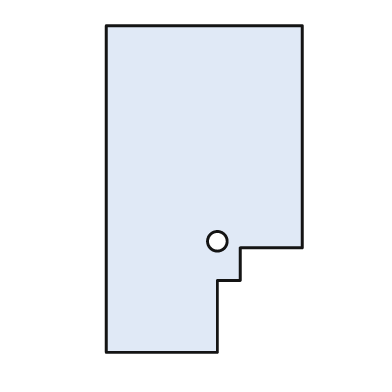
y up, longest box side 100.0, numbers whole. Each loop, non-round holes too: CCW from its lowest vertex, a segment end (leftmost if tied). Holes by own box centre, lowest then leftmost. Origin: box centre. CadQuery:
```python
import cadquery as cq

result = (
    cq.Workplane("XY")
    .moveTo(-30.0, -50.0)
    .lineTo(4.0, -50.0)
    .lineTo(4.0, -28.0)
    .lineTo(11.0, -28.0)
    .lineTo(11.0, -18.0)
    .lineTo(30.0, -18.0)
    .lineTo(30.0, 50.0)
    .lineTo(-30.0, 50.0)
    .close()
    .moveTo(4.0, -16.0)
    .circle(3.0)
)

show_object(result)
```